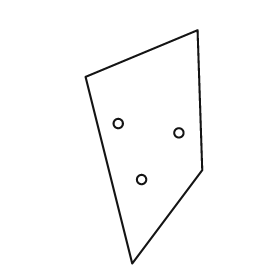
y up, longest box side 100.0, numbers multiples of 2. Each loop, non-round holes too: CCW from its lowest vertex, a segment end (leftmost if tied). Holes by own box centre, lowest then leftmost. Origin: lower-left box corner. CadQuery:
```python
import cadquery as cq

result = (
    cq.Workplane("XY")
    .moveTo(20.0, 0.0)
    .lineTo(50.0, 40.0)
    .lineTo(48.0, 100.0)
    .lineTo(0.0, 80.0)
    .close()
    .moveTo(24.0, 36.0)
    .circle(2.0)
    .moveTo(40.0, 56.0)
    .circle(2.0)
    .moveTo(14.0, 60.0)
    .circle(2.0)
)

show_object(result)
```